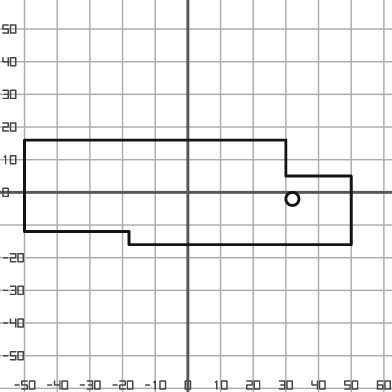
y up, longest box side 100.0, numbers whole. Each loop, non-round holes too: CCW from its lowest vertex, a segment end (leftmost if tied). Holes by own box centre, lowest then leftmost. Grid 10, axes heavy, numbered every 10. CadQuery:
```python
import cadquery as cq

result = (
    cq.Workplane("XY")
    .moveTo(-18.0, -16.0)
    .lineTo(50.0, -16.0)
    .lineTo(50.0, 5.0)
    .lineTo(30.0, 5.0)
    .lineTo(30.0, 16.0)
    .lineTo(-50.0, 16.0)
    .lineTo(-50.0, -12.0)
    .lineTo(-18.0, -12.0)
    .close()
    .moveTo(32.0, -2.0)
    .circle(2.0)
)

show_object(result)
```